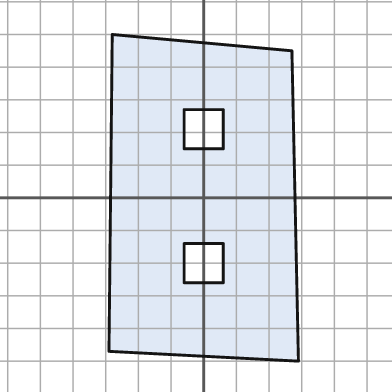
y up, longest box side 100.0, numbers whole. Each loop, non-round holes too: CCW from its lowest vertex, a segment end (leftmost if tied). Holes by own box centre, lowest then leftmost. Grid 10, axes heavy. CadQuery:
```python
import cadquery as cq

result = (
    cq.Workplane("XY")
    .moveTo(29.0, -50.0)
    .lineTo(27.0, 45.0)
    .lineTo(-28.0, 50.0)
    .lineTo(-29.0, -47.0)
    .close()
    .moveTo(-6.0, -26.0)
    .lineTo(6.0, -26.0)
    .lineTo(6.0, -14.0)
    .lineTo(-6.0, -14.0)
    .close()
    .moveTo(-6.0, 15.0)
    .lineTo(6.0, 15.0)
    .lineTo(6.0, 27.0)
    .lineTo(-6.0, 27.0)
    .close()
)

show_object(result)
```